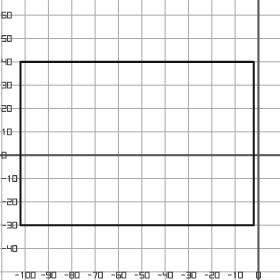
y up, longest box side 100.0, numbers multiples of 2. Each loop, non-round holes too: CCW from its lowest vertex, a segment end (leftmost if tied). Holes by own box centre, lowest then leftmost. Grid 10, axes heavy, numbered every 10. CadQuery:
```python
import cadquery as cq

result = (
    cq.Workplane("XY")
    .moveTo(-102.0, -30.0)
    .lineTo(-2.0, -30.0)
    .lineTo(-2.0, 40.0)
    .lineTo(-102.0, 40.0)
    .close()
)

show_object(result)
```